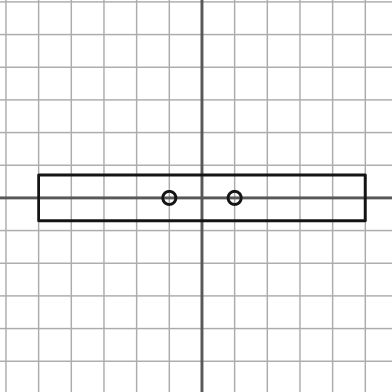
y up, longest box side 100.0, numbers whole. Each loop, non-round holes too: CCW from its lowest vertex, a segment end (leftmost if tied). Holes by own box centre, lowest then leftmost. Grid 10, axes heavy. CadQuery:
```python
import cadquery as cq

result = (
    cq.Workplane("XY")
    .moveTo(-50.0, -7.0)
    .lineTo(50.0, -7.0)
    .lineTo(50.0, 7.0)
    .lineTo(-50.0, 7.0)
    .close()
    .moveTo(-10.0, 0.0)
    .circle(2.0)
    .moveTo(10.0, 0.0)
    .circle(2.0)
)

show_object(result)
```